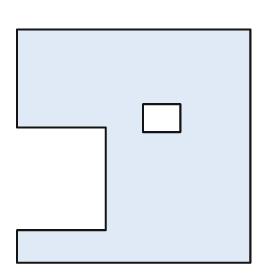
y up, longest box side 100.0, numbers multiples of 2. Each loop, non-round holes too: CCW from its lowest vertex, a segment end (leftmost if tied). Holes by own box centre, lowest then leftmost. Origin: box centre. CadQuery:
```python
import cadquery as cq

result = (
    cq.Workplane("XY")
    .moveTo(-50.0, -50.0)
    .lineTo(50.0, -50.0)
    .lineTo(50.0, 50.0)
    .lineTo(-50.0, 50.0)
    .lineTo(-50.0, 8.0)
    .lineTo(-12.0, 8.0)
    .lineTo(-12.0, -36.0)
    .lineTo(-50.0, -36.0)
    .close()
    .moveTo(4.0, 6.0)
    .lineTo(20.0, 6.0)
    .lineTo(20.0, 18.0)
    .lineTo(4.0, 18.0)
    .close()
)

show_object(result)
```